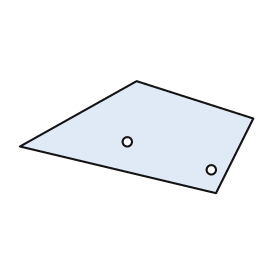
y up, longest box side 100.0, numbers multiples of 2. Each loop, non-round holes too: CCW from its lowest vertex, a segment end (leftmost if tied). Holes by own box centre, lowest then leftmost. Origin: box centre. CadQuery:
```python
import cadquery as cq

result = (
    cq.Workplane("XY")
    .moveTo(34.0, -24.0)
    .lineTo(50.0, 8.0)
    .lineTo(0.0, 24.0)
    .lineTo(-50.0, -4.0)
    .close()
    .moveTo(32.0, -14.0)
    .circle(2.0)
    .moveTo(-4.0, -2.0)
    .circle(2.0)
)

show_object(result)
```